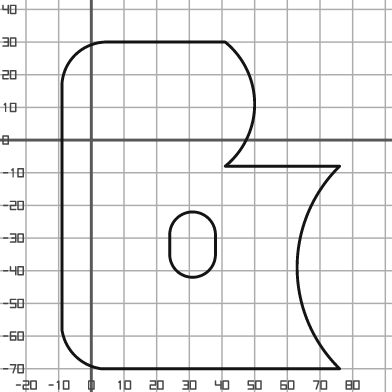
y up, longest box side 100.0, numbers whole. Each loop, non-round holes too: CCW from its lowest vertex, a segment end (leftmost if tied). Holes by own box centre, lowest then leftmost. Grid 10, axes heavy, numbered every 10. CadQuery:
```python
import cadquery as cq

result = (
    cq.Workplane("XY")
    .moveTo(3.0, -70.0)
    .lineTo(76.0, -70.0)
    .threePointArc((63.0, -39.0), (76.0, -8.0))
    .lineTo(41.0, -8.0)
    .threePointArc((50.0, 11.0), (41.0, 30.0))
    .lineTo(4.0, 30.0)
    .threePointArc((-5.0, 26.0), (-9.0, 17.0))
    .lineTo(-9.0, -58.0)
    .threePointArc((-5.0, -66.0), (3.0, -70.0))
    .close()
    .moveTo(24.0, -35.0)
    .threePointArc((31.0, -42.0), (38.0, -35.0))
    .lineTo(38.0, -29.0)
    .threePointArc((31.0, -22.0), (24.0, -29.0))
    .close()
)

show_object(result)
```